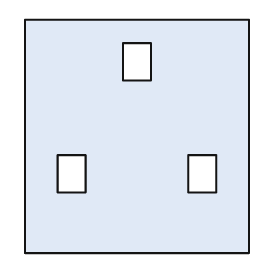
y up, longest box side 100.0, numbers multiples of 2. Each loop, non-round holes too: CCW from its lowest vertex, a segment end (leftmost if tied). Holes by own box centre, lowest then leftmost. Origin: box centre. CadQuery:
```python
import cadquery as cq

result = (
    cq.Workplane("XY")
    .moveTo(-48.0, -50.0)
    .lineTo(48.0, -50.0)
    .lineTo(48.0, 50.0)
    .lineTo(-48.0, 50.0)
    .close()
    .moveTo(-34.0, -24.0)
    .lineTo(-22.0, -24.0)
    .lineTo(-22.0, -8.0)
    .lineTo(-34.0, -8.0)
    .close()
    .moveTo(22.0, -24.0)
    .lineTo(34.0, -24.0)
    .lineTo(34.0, -8.0)
    .lineTo(22.0, -8.0)
    .close()
    .moveTo(-6.0, 24.0)
    .lineTo(6.0, 24.0)
    .lineTo(6.0, 40.0)
    .lineTo(-6.0, 40.0)
    .close()
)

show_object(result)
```